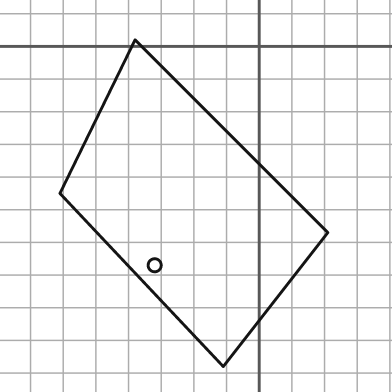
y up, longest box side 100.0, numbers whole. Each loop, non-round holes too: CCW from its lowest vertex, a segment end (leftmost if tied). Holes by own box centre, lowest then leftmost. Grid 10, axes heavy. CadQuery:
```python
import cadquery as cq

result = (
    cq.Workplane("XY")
    .moveTo(-11.0, -98.0)
    .lineTo(21.0, -57.0)
    .lineTo(-38.0, 2.0)
    .lineTo(-61.0, -45.0)
    .close()
    .moveTo(-32.0, -67.0)
    .circle(2.0)
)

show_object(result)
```